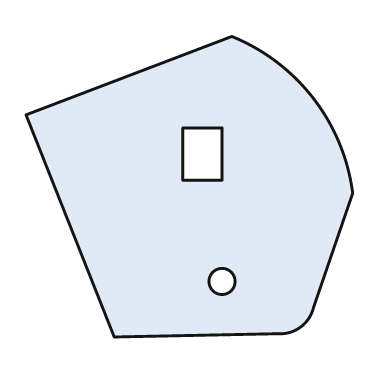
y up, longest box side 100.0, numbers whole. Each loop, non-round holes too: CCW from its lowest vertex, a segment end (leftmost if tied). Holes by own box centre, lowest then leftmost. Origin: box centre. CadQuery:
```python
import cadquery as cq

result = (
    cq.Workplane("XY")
    .moveTo(-23.0, -46.0)
    .lineTo(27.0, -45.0)
    .threePointArc((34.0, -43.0), (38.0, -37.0))
    .lineTo(50.0, -2.0)
    .threePointArc((38.0, 27.0), (13.0, 46.0))
    .lineTo(-50.0, 22.0)
    .close()
    .moveTo(10.0, -29.0)
    .circle(4.0)
    .moveTo(-2.0, 2.0)
    .lineTo(10.0, 2.0)
    .lineTo(10.0, 18.0)
    .lineTo(-2.0, 18.0)
    .close()
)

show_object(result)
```